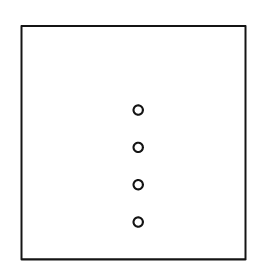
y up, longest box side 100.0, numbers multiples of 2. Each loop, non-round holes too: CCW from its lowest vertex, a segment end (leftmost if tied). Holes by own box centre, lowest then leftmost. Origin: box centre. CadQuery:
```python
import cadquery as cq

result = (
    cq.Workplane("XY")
    .moveTo(-48.0, -50.0)
    .lineTo(48.0, -50.0)
    .lineTo(48.0, 50.0)
    .lineTo(-48.0, 50.0)
    .close()
    .moveTo(2.0, -34.0)
    .circle(2.0)
    .moveTo(2.0, -18.0)
    .circle(2.0)
    .moveTo(2.0, -2.0)
    .circle(2.0)
    .moveTo(2.0, 14.0)
    .circle(2.0)
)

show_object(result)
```